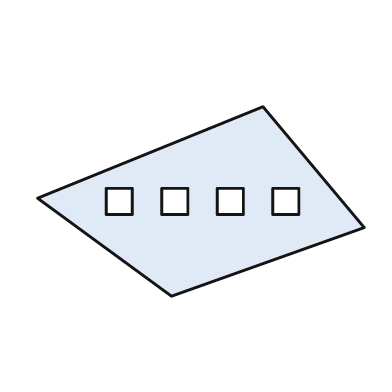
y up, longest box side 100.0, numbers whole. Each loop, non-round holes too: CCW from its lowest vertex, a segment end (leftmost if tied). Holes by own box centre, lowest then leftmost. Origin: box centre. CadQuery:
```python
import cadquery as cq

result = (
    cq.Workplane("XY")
    .moveTo(-9.0, -29.0)
    .lineTo(50.0, -8.0)
    .lineTo(19.0, 29.0)
    .lineTo(-50.0, 1.0)
    .close()
    .moveTo(-29.0, -4.0)
    .lineTo(-21.0, -4.0)
    .lineTo(-21.0, 4.0)
    .lineTo(-29.0, 4.0)
    .close()
    .moveTo(-12.0, -4.0)
    .lineTo(-4.0, -4.0)
    .lineTo(-4.0, 4.0)
    .lineTo(-12.0, 4.0)
    .close()
    .moveTo(5.0, -4.0)
    .lineTo(13.0, -4.0)
    .lineTo(13.0, 4.0)
    .lineTo(5.0, 4.0)
    .close()
    .moveTo(22.0, -4.0)
    .lineTo(30.0, -4.0)
    .lineTo(30.0, 4.0)
    .lineTo(22.0, 4.0)
    .close()
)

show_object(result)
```